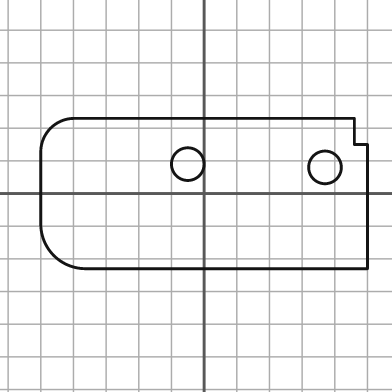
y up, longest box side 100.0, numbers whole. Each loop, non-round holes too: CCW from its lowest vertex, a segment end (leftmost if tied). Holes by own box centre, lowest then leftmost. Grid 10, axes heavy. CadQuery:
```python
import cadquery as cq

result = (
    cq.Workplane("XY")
    .moveTo(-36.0, -23.0)
    .lineTo(50.0, -23.0)
    .lineTo(50.0, 15.0)
    .lineTo(46.0, 15.0)
    .lineTo(46.0, 23.0)
    .lineTo(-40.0, 23.0)
    .threePointArc((-47.0, 20.0), (-50.0, 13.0))
    .lineTo(-50.0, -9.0)
    .threePointArc((-46.0, -19.0), (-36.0, -23.0))
    .close()
    .moveTo(37.0, 8.0)
    .circle(5.0)
    .moveTo(-5.0, 9.0)
    .circle(5.0)
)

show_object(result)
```